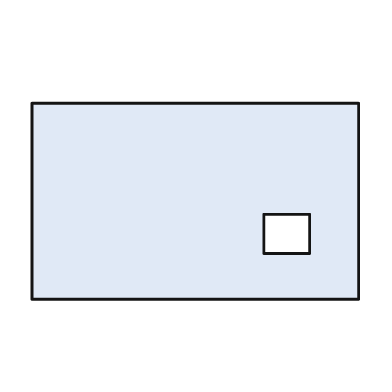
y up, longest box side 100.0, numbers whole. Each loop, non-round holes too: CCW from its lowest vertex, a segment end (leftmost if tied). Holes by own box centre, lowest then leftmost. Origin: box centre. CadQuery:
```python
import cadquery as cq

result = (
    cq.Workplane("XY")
    .moveTo(-50.0, -30.0)
    .lineTo(50.0, -30.0)
    .lineTo(50.0, 30.0)
    .lineTo(-50.0, 30.0)
    .close()
    .moveTo(21.0, -16.0)
    .lineTo(35.0, -16.0)
    .lineTo(35.0, -4.0)
    .lineTo(21.0, -4.0)
    .close()
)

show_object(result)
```